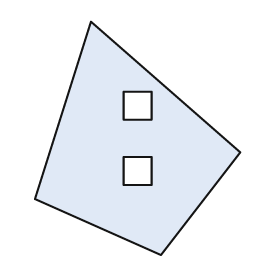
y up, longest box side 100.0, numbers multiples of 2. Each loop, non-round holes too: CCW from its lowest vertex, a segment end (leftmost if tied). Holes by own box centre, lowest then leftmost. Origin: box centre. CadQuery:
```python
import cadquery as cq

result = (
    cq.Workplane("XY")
    .moveTo(10.0, -50.0)
    .lineTo(44.0, -6.0)
    .lineTo(-20.0, 50.0)
    .lineTo(-44.0, -26.0)
    .close()
    .moveTo(-6.0, -20.0)
    .lineTo(6.0, -20.0)
    .lineTo(6.0, -8.0)
    .lineTo(-6.0, -8.0)
    .close()
    .moveTo(-6.0, 8.0)
    .lineTo(6.0, 8.0)
    .lineTo(6.0, 20.0)
    .lineTo(-6.0, 20.0)
    .close()
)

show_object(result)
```